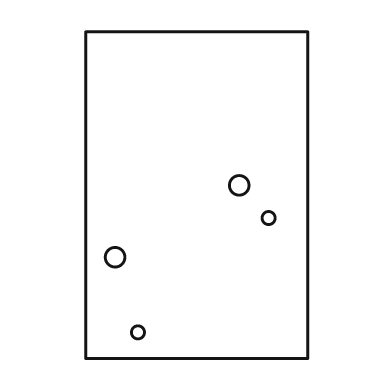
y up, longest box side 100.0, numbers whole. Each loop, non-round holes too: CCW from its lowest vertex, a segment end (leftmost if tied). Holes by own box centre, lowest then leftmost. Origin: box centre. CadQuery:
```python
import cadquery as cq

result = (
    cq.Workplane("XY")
    .moveTo(-34.0, -50.0)
    .lineTo(34.0, -50.0)
    .lineTo(34.0, 50.0)
    .lineTo(-34.0, 50.0)
    .close()
    .moveTo(-18.0, -42.0)
    .circle(2.0)
    .moveTo(-25.0, -19.0)
    .circle(3.0)
    .moveTo(22.0, -7.0)
    .circle(2.0)
    .moveTo(13.0, 3.0)
    .circle(3.0)
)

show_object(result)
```